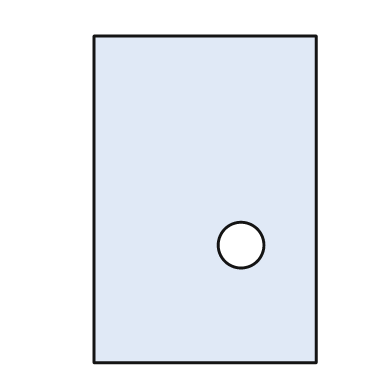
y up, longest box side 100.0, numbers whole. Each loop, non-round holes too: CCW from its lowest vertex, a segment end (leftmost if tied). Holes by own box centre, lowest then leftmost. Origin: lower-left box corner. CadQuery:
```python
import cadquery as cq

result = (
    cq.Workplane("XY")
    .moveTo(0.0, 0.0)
    .lineTo(68.0, 0.0)
    .lineTo(68.0, 100.0)
    .lineTo(0.0, 100.0)
    .close()
    .moveTo(45.0, 36.0)
    .circle(7.0)
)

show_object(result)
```